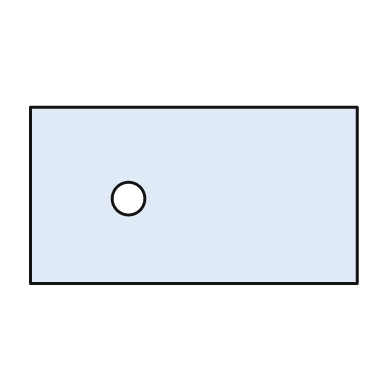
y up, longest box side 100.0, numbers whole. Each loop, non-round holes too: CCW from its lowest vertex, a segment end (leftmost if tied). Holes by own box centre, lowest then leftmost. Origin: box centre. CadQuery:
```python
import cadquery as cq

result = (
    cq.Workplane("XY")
    .moveTo(-50.0, -27.0)
    .lineTo(50.0, -27.0)
    .lineTo(50.0, 27.0)
    .lineTo(-50.0, 27.0)
    .close()
    .moveTo(-20.0, -1.0)
    .circle(5.0)
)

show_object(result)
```